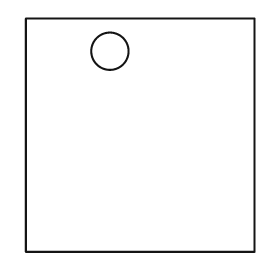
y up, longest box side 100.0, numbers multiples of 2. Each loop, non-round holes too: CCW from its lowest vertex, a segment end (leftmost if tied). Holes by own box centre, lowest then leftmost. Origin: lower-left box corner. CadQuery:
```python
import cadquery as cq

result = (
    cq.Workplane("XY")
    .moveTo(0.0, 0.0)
    .lineTo(98.0, 0.0)
    .lineTo(98.0, 100.0)
    .lineTo(0.0, 100.0)
    .close()
    .moveTo(36.0, 86.0)
    .circle(8.0)
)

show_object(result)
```